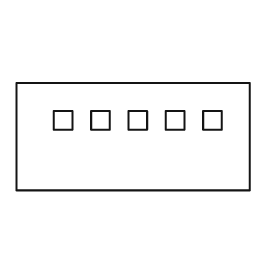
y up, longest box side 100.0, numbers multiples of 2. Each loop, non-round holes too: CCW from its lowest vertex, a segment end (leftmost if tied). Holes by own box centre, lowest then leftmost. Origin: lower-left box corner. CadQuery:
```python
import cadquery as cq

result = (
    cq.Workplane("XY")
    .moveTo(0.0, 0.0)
    .lineTo(100.0, 0.0)
    .lineTo(100.0, 46.0)
    .lineTo(0.0, 46.0)
    .close()
    .moveTo(16.0, 26.0)
    .lineTo(24.0, 26.0)
    .lineTo(24.0, 34.0)
    .lineTo(16.0, 34.0)
    .close()
    .moveTo(32.0, 26.0)
    .lineTo(40.0, 26.0)
    .lineTo(40.0, 34.0)
    .lineTo(32.0, 34.0)
    .close()
    .moveTo(48.0, 26.0)
    .lineTo(56.0, 26.0)
    .lineTo(56.0, 34.0)
    .lineTo(48.0, 34.0)
    .close()
    .moveTo(64.0, 26.0)
    .lineTo(72.0, 26.0)
    .lineTo(72.0, 34.0)
    .lineTo(64.0, 34.0)
    .close()
    .moveTo(80.0, 26.0)
    .lineTo(88.0, 26.0)
    .lineTo(88.0, 34.0)
    .lineTo(80.0, 34.0)
    .close()
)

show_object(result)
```